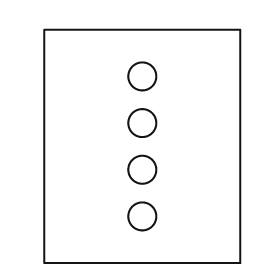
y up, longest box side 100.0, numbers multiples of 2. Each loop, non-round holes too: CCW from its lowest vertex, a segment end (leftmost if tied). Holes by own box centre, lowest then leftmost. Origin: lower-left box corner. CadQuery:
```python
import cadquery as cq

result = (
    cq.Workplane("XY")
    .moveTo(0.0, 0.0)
    .lineTo(84.0, 0.0)
    .lineTo(84.0, 100.0)
    .lineTo(0.0, 100.0)
    .close()
    .moveTo(42.0, 20.0)
    .circle(6.0)
    .moveTo(42.0, 40.0)
    .circle(6.0)
    .moveTo(42.0, 60.0)
    .circle(6.0)
    .moveTo(42.0, 80.0)
    .circle(6.0)
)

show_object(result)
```